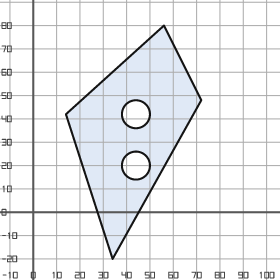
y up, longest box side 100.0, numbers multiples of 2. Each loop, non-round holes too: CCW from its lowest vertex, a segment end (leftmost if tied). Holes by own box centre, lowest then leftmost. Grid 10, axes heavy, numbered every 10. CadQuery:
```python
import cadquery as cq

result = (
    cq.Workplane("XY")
    .moveTo(34.0, -20.0)
    .lineTo(72.0, 48.0)
    .lineTo(56.0, 80.0)
    .lineTo(14.0, 42.0)
    .close()
    .moveTo(44.0, 20.0)
    .circle(6.0)
    .moveTo(44.0, 42.0)
    .circle(6.0)
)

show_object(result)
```